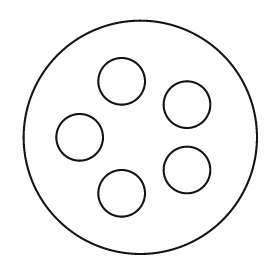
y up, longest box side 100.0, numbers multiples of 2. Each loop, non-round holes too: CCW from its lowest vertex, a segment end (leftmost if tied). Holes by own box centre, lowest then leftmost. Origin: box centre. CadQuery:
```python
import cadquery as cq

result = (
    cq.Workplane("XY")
    .moveTo(0.0, 0.0)
    .circle(50.0)
    .moveTo(-8.0, -24.0)
    .circle(10.0)
    .moveTo(20.0, -14.0)
    .circle(10.0)
    .moveTo(-26.0, 0.0)
    .circle(10.0)
    .moveTo(20.0, 14.0)
    .circle(10.0)
    .moveTo(-8.0, 24.0)
    .circle(10.0)
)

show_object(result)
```